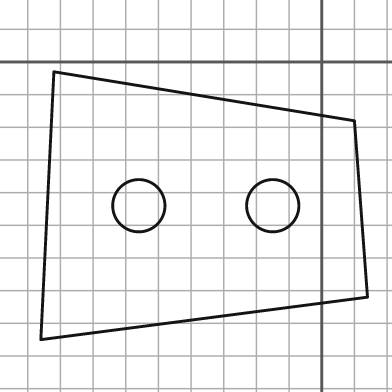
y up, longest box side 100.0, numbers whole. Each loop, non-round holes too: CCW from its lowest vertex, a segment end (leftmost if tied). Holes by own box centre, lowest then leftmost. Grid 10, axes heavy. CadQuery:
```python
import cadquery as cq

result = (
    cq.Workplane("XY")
    .moveTo(-86.0, -85.0)
    .lineTo(14.0, -72.0)
    .lineTo(10.0, -18.0)
    .lineTo(-82.0, -3.0)
    .close()
    .moveTo(-56.0, -44.0)
    .circle(8.0)
    .moveTo(-15.0, -44.0)
    .circle(8.0)
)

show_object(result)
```